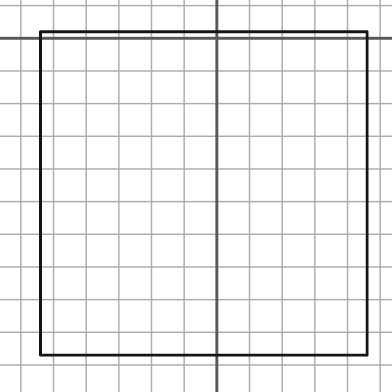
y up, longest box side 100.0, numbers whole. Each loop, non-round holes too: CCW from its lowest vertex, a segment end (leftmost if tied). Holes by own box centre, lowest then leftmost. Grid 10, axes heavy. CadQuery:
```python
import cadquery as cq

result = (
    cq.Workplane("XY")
    .moveTo(-54.0, -97.0)
    .lineTo(46.0, -97.0)
    .lineTo(46.0, 2.0)
    .lineTo(-54.0, 2.0)
    .close()
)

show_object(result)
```